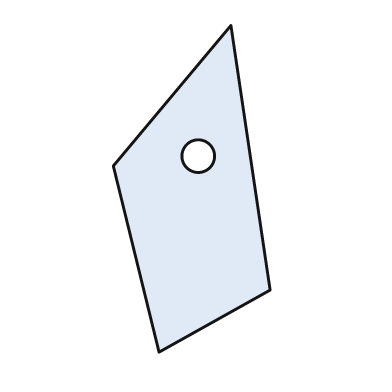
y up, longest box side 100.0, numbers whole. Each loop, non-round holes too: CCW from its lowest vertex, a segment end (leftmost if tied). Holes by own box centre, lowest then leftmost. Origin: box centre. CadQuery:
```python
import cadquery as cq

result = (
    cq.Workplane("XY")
    .moveTo(-10.0, -50.0)
    .lineTo(24.0, -31.0)
    .lineTo(12.0, 50.0)
    .lineTo(-24.0, 7.0)
    .close()
    .moveTo(2.0, 10.0)
    .circle(5.0)
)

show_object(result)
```